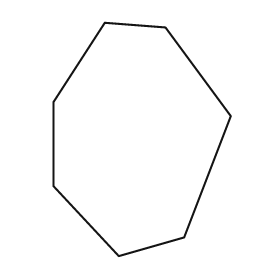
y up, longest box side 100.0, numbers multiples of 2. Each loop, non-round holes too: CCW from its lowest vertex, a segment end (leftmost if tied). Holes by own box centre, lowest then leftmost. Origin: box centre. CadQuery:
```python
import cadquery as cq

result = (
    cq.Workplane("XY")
    .moveTo(-10.0, -50.0)
    .lineTo(18.0, -42.0)
    .lineTo(38.0, 10.0)
    .lineTo(10.0, 48.0)
    .lineTo(-16.0, 50.0)
    .lineTo(-38.0, 16.0)
    .lineTo(-38.0, -20.0)
    .close()
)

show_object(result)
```